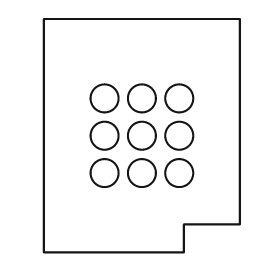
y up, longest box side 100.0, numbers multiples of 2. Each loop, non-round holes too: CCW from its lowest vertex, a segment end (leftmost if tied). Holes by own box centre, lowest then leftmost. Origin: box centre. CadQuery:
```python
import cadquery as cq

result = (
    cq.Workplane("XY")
    .moveTo(-42.0, -50.0)
    .lineTo(18.0, -50.0)
    .lineTo(18.0, -38.0)
    .lineTo(42.0, -38.0)
    .lineTo(42.0, 50.0)
    .lineTo(-42.0, 50.0)
    .close()
    .moveTo(-16.0, -16.0)
    .circle(6.0)
    .moveTo(0.0, -16.0)
    .circle(6.0)
    .moveTo(16.0, -16.0)
    .circle(6.0)
    .moveTo(-16.0, 0.0)
    .circle(6.0)
    .moveTo(0.0, 0.0)
    .circle(6.0)
    .moveTo(16.0, 0.0)
    .circle(6.0)
    .moveTo(-16.0, 16.0)
    .circle(6.0)
    .moveTo(0.0, 16.0)
    .circle(6.0)
    .moveTo(16.0, 16.0)
    .circle(6.0)
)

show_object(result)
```